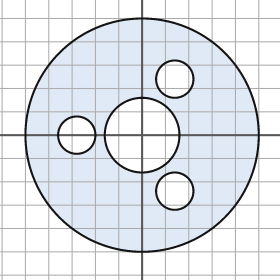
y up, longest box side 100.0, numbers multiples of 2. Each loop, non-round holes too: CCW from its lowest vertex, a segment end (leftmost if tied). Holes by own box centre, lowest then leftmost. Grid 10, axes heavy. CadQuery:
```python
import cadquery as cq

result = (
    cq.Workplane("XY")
    .moveTo(0.0, 0.0)
    .circle(50.0)
    .moveTo(14.0, -24.0)
    .circle(8.0)
    .moveTo(-28.0, 0.0)
    .circle(8.0)
    .moveTo(0.0, 0.0)
    .circle(16.0)
    .moveTo(14.0, 24.0)
    .circle(8.0)
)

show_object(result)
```